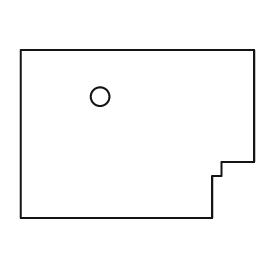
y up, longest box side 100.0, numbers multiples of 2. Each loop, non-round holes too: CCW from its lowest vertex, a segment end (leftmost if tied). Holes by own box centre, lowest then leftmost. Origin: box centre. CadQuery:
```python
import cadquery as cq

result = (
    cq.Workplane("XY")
    .moveTo(-50.0, -36.0)
    .lineTo(32.0, -36.0)
    .lineTo(32.0, -18.0)
    .lineTo(36.0, -18.0)
    .lineTo(36.0, -12.0)
    .lineTo(50.0, -12.0)
    .lineTo(50.0, 36.0)
    .lineTo(-50.0, 36.0)
    .close()
    .moveTo(-16.0, 16.0)
    .circle(4.0)
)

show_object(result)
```